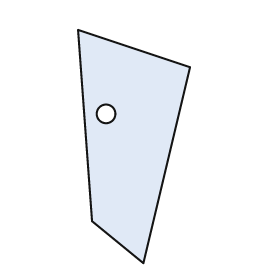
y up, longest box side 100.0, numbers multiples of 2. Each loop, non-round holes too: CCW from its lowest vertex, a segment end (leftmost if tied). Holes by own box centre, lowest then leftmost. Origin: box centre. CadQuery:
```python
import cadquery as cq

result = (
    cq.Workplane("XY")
    .moveTo(4.0, -50.0)
    .lineTo(24.0, 34.0)
    .lineTo(-24.0, 50.0)
    .lineTo(-18.0, -32.0)
    .close()
    .moveTo(-12.0, 14.0)
    .circle(4.0)
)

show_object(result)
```